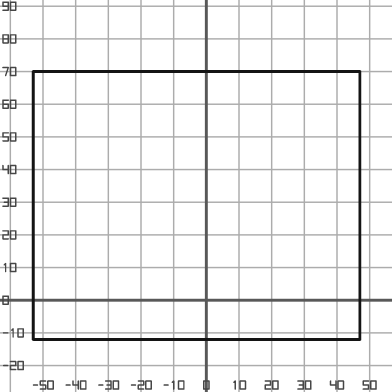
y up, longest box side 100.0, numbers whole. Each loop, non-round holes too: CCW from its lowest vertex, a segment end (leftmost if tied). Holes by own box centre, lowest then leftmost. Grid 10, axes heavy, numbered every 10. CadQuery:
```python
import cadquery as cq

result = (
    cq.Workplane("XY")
    .moveTo(-53.0, -12.0)
    .lineTo(47.0, -12.0)
    .lineTo(47.0, 70.0)
    .lineTo(-53.0, 70.0)
    .close()
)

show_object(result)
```